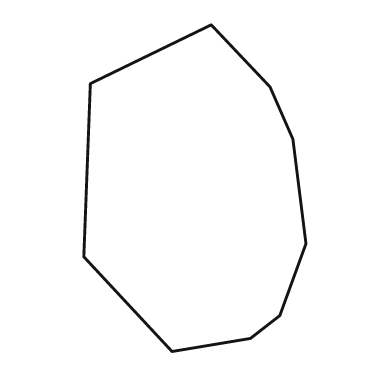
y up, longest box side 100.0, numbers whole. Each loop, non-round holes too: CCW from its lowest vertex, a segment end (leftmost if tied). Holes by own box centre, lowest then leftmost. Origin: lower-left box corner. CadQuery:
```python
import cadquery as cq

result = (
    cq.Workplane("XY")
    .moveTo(27.0, 0.0)
    .lineTo(51.0, 4.0)
    .lineTo(60.0, 11.0)
    .lineTo(68.0, 33.0)
    .lineTo(64.0, 65.0)
    .lineTo(57.0, 81.0)
    .lineTo(39.0, 100.0)
    .lineTo(2.0, 82.0)
    .lineTo(0.0, 29.0)
    .close()
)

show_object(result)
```